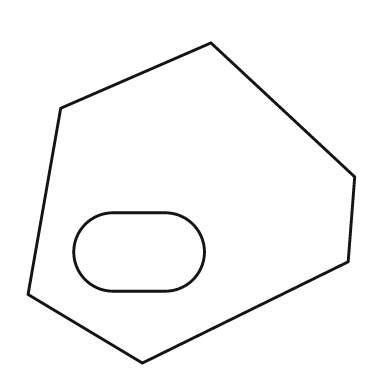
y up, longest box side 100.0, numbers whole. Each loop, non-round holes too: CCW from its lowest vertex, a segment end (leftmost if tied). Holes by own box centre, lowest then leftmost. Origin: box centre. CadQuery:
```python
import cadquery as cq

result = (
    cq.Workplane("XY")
    .moveTo(-15.0, -49.0)
    .lineTo(48.0, -18.0)
    .lineTo(50.0, 8.0)
    .lineTo(6.0, 49.0)
    .lineTo(-40.0, 29.0)
    .lineTo(-50.0, -28.0)
    .close()
    .moveTo(-24.0, -27.0)
    .lineTo(-8.0, -27.0)
    .threePointArc((4.0, -15.0), (-8.0, -3.0))
    .lineTo(-24.0, -3.0)
    .threePointArc((-36.0, -15.0), (-24.0, -27.0))
    .close()
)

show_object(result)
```